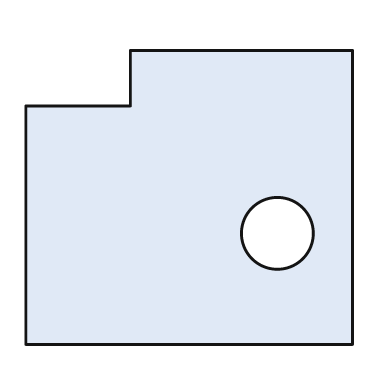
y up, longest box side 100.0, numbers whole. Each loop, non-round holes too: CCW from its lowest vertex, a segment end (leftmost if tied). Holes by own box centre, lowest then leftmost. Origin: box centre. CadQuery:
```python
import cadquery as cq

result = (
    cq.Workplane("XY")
    .moveTo(-50.0, -45.0)
    .lineTo(50.0, -45.0)
    .lineTo(50.0, 45.0)
    .lineTo(-18.0, 45.0)
    .lineTo(-18.0, 28.0)
    .lineTo(-50.0, 28.0)
    .close()
    .moveTo(27.0, -11.0)
    .circle(11.0)
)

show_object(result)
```